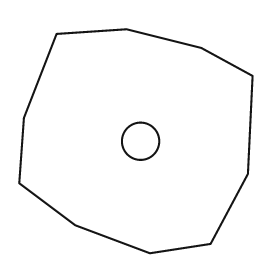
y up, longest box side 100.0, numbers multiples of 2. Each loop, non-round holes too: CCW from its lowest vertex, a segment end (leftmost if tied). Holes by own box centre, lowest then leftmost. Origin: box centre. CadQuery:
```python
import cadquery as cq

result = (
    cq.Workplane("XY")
    .moveTo(6.0, -48.0)
    .lineTo(32.0, -44.0)
    .lineTo(48.0, -14.0)
    .lineTo(50.0, 28.0)
    .lineTo(28.0, 40.0)
    .lineTo(-4.0, 48.0)
    .lineTo(-34.0, 46.0)
    .lineTo(-48.0, 10.0)
    .lineTo(-50.0, -18.0)
    .lineTo(-26.0, -36.0)
    .close()
    .moveTo(2.0, 0.0)
    .circle(8.0)
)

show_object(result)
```